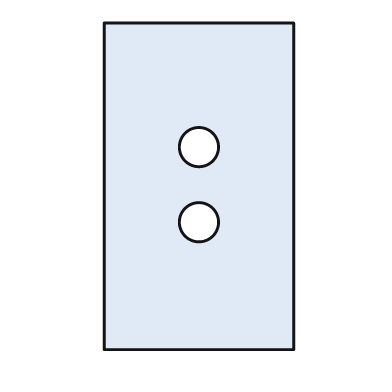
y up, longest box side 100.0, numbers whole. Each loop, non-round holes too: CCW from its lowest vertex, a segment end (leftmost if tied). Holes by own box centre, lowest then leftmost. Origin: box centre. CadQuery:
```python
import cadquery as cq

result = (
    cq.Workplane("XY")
    .moveTo(-29.0, -50.0)
    .lineTo(29.0, -50.0)
    .lineTo(29.0, 50.0)
    .lineTo(-29.0, 50.0)
    .close()
    .moveTo(0.0, -11.0)
    .circle(6.0)
    .moveTo(0.0, 12.0)
    .circle(6.0)
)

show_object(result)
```